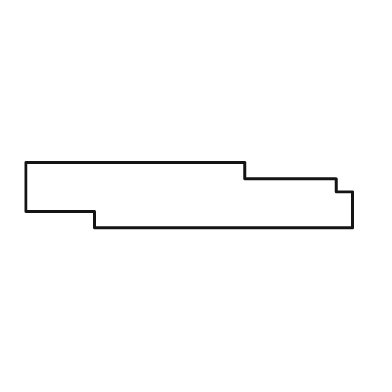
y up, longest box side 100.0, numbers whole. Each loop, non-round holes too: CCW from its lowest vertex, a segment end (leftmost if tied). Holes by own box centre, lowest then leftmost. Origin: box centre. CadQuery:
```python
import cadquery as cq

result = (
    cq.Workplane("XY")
    .moveTo(-29.0, -10.0)
    .lineTo(50.0, -10.0)
    .lineTo(50.0, 1.0)
    .lineTo(45.0, 1.0)
    .lineTo(45.0, 5.0)
    .lineTo(17.0, 5.0)
    .lineTo(17.0, 10.0)
    .lineTo(-50.0, 10.0)
    .lineTo(-50.0, -5.0)
    .lineTo(-29.0, -5.0)
    .close()
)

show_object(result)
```